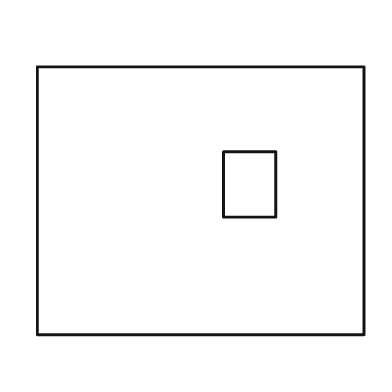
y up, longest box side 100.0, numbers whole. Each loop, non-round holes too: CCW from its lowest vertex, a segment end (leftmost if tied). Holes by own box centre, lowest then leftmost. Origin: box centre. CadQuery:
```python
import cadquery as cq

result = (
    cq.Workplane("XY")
    .moveTo(-50.0, -41.0)
    .lineTo(50.0, -41.0)
    .lineTo(50.0, 41.0)
    .lineTo(-50.0, 41.0)
    .close()
    .moveTo(7.0, -5.0)
    .lineTo(23.0, -5.0)
    .lineTo(23.0, 15.0)
    .lineTo(7.0, 15.0)
    .close()
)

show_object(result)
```